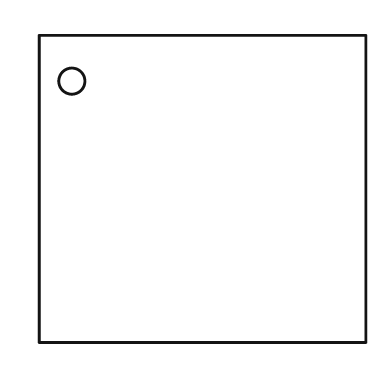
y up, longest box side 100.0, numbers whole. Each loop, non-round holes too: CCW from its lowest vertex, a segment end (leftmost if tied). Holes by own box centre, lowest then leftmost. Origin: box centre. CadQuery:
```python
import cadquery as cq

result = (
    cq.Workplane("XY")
    .moveTo(-50.0, -47.0)
    .lineTo(50.0, -47.0)
    .lineTo(50.0, 47.0)
    .lineTo(-50.0, 47.0)
    .close()
    .moveTo(-40.0, 33.0)
    .circle(4.0)
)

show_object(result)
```